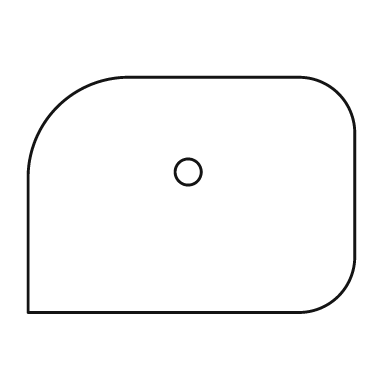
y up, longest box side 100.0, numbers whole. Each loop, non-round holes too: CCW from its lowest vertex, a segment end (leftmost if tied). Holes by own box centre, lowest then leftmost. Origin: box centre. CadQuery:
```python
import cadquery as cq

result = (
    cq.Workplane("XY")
    .moveTo(-50.0, -36.0)
    .lineTo(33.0, -36.0)
    .threePointArc((45.0, -31.0), (50.0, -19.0))
    .lineTo(50.0, 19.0)
    .threePointArc((45.0, 31.0), (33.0, 36.0))
    .lineTo(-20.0, 36.0)
    .threePointArc((-41.0, 27.0), (-50.0, 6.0))
    .close()
    .moveTo(-1.0, 7.0)
    .circle(4.0)
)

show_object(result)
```